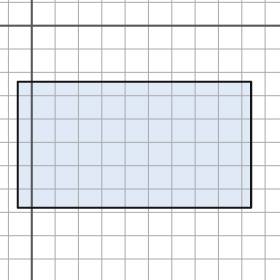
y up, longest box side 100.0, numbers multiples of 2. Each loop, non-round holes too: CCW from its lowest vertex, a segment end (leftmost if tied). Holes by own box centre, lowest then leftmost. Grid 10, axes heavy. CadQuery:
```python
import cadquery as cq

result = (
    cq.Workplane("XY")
    .moveTo(-6.0, -78.0)
    .lineTo(94.0, -78.0)
    .lineTo(94.0, -24.0)
    .lineTo(-6.0, -24.0)
    .close()
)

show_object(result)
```